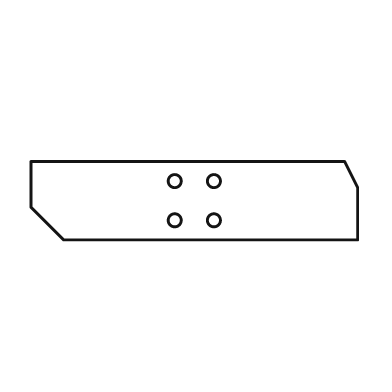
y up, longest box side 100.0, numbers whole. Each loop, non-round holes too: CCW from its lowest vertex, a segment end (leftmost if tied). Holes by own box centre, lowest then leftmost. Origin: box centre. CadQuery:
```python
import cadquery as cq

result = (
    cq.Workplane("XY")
    .moveTo(-40.0, -12.0)
    .lineTo(50.0, -12.0)
    .lineTo(50.0, 4.0)
    .lineTo(46.0, 12.0)
    .lineTo(-50.0, 12.0)
    .lineTo(-50.0, -2.0)
    .close()
    .moveTo(-6.0, -6.0)
    .circle(2.0)
    .moveTo(6.0, -6.0)
    .circle(2.0)
    .moveTo(-6.0, 6.0)
    .circle(2.0)
    .moveTo(6.0, 6.0)
    .circle(2.0)
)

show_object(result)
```